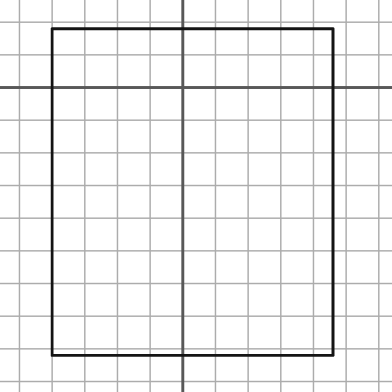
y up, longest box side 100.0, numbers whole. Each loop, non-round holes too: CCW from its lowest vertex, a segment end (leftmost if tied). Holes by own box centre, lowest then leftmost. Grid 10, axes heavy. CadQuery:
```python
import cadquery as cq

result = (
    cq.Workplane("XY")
    .moveTo(-40.0, -82.0)
    .lineTo(46.0, -82.0)
    .lineTo(46.0, 18.0)
    .lineTo(-40.0, 18.0)
    .close()
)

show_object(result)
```